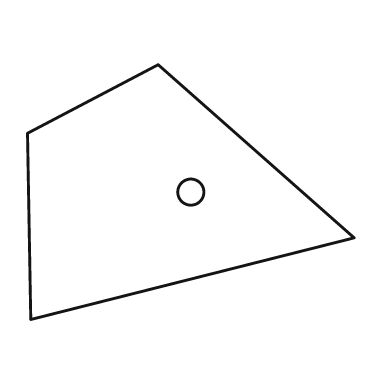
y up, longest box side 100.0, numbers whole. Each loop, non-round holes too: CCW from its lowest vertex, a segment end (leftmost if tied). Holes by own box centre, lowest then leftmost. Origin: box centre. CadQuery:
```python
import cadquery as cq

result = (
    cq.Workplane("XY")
    .moveTo(-49.0, -39.0)
    .lineTo(50.0, -14.0)
    .lineTo(-10.0, 39.0)
    .lineTo(-50.0, 18.0)
    .close()
    .moveTo(0.0, 0.0)
    .circle(4.0)
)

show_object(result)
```